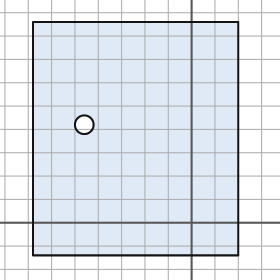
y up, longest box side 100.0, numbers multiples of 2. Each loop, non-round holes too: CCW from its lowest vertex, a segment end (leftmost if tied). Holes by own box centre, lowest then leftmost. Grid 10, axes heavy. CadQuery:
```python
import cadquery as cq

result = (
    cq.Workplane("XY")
    .moveTo(-68.0, -14.0)
    .lineTo(20.0, -14.0)
    .lineTo(20.0, 86.0)
    .lineTo(-68.0, 86.0)
    .close()
    .moveTo(-46.0, 42.0)
    .circle(4.0)
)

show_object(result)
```